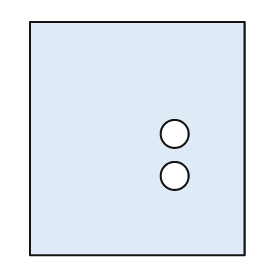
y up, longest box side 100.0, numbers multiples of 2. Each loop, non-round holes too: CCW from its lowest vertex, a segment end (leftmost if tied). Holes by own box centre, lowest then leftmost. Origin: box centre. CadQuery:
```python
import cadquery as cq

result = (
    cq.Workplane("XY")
    .moveTo(-46.0, -50.0)
    .lineTo(46.0, -50.0)
    .lineTo(46.0, 50.0)
    .lineTo(-46.0, 50.0)
    .close()
    .moveTo(16.0, -16.0)
    .circle(6.0)
    .moveTo(16.0, 2.0)
    .circle(6.0)
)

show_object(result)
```